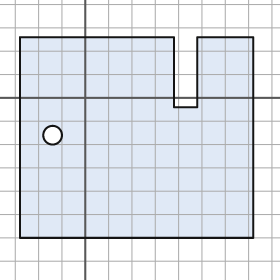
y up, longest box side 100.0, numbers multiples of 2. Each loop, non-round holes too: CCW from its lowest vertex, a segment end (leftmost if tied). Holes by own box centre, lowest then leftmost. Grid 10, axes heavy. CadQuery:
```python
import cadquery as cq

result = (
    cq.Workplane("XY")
    .moveTo(-28.0, -60.0)
    .lineTo(72.0, -60.0)
    .lineTo(72.0, 26.0)
    .lineTo(48.0, 26.0)
    .lineTo(48.0, -4.0)
    .lineTo(38.0, -4.0)
    .lineTo(38.0, 26.0)
    .lineTo(-28.0, 26.0)
    .close()
    .moveTo(-14.0, -16.0)
    .circle(4.0)
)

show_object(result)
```